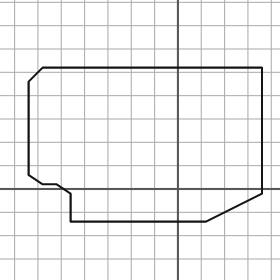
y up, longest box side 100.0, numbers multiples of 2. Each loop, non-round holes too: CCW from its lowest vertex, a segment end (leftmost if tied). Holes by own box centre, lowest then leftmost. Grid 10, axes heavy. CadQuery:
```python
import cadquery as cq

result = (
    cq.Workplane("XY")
    .moveTo(-46.0, -14.0)
    .lineTo(12.0, -14.0)
    .lineTo(36.0, -2.0)
    .lineTo(36.0, 52.0)
    .lineTo(-58.0, 52.0)
    .lineTo(-64.0, 46.0)
    .lineTo(-64.0, 6.0)
    .lineTo(-58.0, 2.0)
    .lineTo(-52.0, 2.0)
    .lineTo(-46.0, -2.0)
    .close()
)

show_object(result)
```